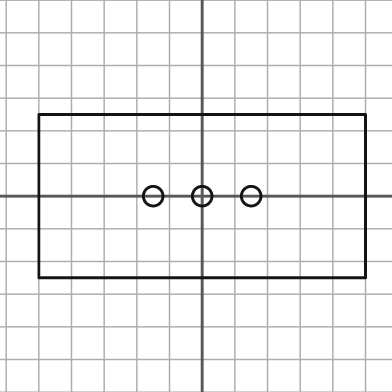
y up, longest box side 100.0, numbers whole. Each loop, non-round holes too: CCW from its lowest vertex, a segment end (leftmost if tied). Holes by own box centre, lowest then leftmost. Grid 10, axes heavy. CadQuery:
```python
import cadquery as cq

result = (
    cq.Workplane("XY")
    .moveTo(-50.0, -25.0)
    .lineTo(50.0, -25.0)
    .lineTo(50.0, 25.0)
    .lineTo(-50.0, 25.0)
    .close()
    .moveTo(-15.0, 0.0)
    .circle(3.0)
    .moveTo(0.0, 0.0)
    .circle(3.0)
    .moveTo(15.0, 0.0)
    .circle(3.0)
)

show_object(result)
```